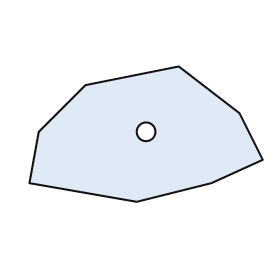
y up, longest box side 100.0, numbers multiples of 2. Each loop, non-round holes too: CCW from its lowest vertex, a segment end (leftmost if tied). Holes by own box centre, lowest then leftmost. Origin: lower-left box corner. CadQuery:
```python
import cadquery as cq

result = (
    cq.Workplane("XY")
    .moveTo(46.0, 0.0)
    .lineTo(78.0, 8.0)
    .lineTo(100.0, 18.0)
    .lineTo(90.0, 38.0)
    .lineTo(64.0, 58.0)
    .lineTo(24.0, 50.0)
    .lineTo(4.0, 30.0)
    .lineTo(0.0, 8.0)
    .close()
    .moveTo(50.0, 30.0)
    .circle(4.0)
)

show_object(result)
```